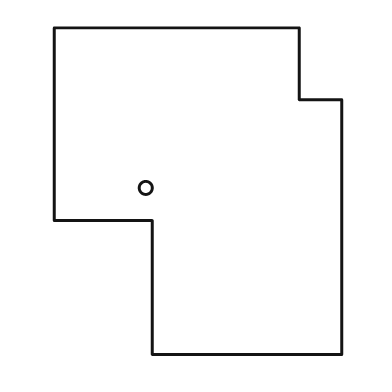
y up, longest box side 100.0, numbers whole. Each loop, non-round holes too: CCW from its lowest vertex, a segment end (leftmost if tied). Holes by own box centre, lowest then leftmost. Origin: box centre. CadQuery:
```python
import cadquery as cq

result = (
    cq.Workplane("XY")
    .moveTo(-14.0, -50.0)
    .lineTo(44.0, -50.0)
    .lineTo(44.0, 28.0)
    .lineTo(31.0, 28.0)
    .lineTo(31.0, 50.0)
    .lineTo(-44.0, 50.0)
    .lineTo(-44.0, -9.0)
    .lineTo(-14.0, -9.0)
    .close()
    .moveTo(-16.0, 1.0)
    .circle(2.0)
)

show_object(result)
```